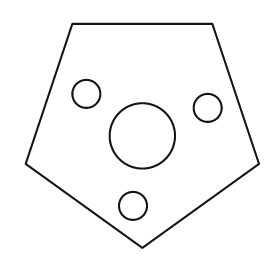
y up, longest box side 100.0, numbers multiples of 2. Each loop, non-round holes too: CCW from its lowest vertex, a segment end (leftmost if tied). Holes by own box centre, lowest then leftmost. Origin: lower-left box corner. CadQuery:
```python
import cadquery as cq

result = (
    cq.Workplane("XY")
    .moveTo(50.0, 0.0)
    .lineTo(100.0, 36.0)
    .lineTo(80.0, 96.0)
    .lineTo(20.0, 96.0)
    .lineTo(0.0, 36.0)
    .close()
    .moveTo(46.0, 18.0)
    .circle(6.0)
    .moveTo(50.0, 48.0)
    .circle(14.0)
    .moveTo(78.0, 60.0)
    .circle(6.0)
    .moveTo(26.0, 66.0)
    .circle(6.0)
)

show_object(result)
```